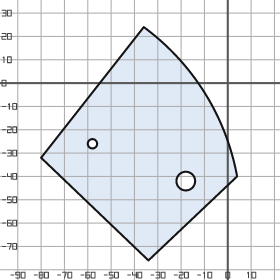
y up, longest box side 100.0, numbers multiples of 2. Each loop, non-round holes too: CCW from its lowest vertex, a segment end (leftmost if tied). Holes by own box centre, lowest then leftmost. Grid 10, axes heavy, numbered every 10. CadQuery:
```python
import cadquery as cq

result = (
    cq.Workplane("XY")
    .moveTo(-34.0, -76.0)
    .lineTo(4.0, -40.0)
    .threePointArc((-10.0, -4.0), (-36.0, 24.0))
    .lineTo(-80.0, -32.0)
    .close()
    .moveTo(-18.0, -42.0)
    .circle(4.0)
    .moveTo(-58.0, -26.0)
    .circle(2.0)
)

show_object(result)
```